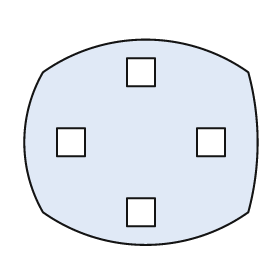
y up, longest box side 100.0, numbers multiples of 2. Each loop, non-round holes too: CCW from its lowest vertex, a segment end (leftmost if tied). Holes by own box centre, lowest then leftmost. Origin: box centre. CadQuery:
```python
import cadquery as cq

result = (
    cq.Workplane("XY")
    .moveTo(-42.0, -30.0)
    .threePointArc((2.0, -44.0), (46.0, -30.0))
    .threePointArc((50.0, 0.0), (46.0, 30.0))
    .threePointArc((2.0, 44.0), (-42.0, 30.0))
    .threePointArc((-50.0, 0.0), (-42.0, -30.0))
    .close()
    .moveTo(-6.0, -36.0)
    .lineTo(6.0, -36.0)
    .lineTo(6.0, -24.0)
    .lineTo(-6.0, -24.0)
    .close()
    .moveTo(-36.0, -6.0)
    .lineTo(-24.0, -6.0)
    .lineTo(-24.0, 6.0)
    .lineTo(-36.0, 6.0)
    .close()
    .moveTo(24.0, -6.0)
    .lineTo(36.0, -6.0)
    .lineTo(36.0, 6.0)
    .lineTo(24.0, 6.0)
    .close()
    .moveTo(-6.0, 24.0)
    .lineTo(6.0, 24.0)
    .lineTo(6.0, 36.0)
    .lineTo(-6.0, 36.0)
    .close()
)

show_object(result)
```